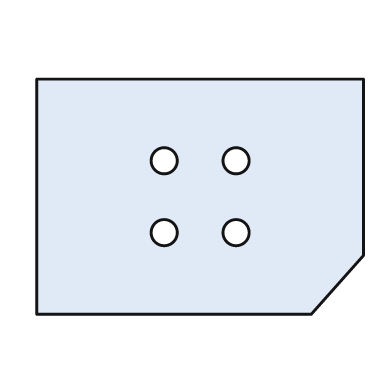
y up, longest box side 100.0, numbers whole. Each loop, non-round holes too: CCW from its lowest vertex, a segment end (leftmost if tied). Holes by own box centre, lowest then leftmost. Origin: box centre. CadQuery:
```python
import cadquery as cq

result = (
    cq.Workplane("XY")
    .moveTo(-50.0, -36.0)
    .lineTo(34.0, -36.0)
    .lineTo(50.0, -18.0)
    .lineTo(50.0, 36.0)
    .lineTo(-50.0, 36.0)
    .close()
    .moveTo(-11.0, -11.0)
    .circle(4.0)
    .moveTo(11.0, -11.0)
    .circle(4.0)
    .moveTo(-11.0, 11.0)
    .circle(4.0)
    .moveTo(11.0, 11.0)
    .circle(4.0)
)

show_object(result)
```